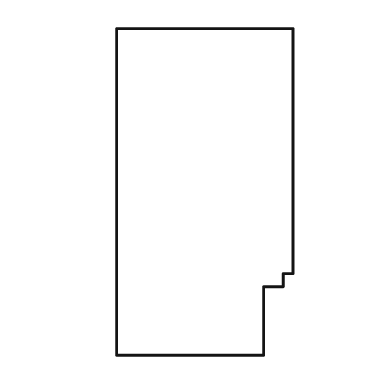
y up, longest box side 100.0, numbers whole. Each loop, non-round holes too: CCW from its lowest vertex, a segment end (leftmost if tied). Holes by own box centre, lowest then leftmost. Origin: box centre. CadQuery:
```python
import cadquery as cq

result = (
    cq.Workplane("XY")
    .moveTo(-27.0, -50.0)
    .lineTo(18.0, -50.0)
    .lineTo(18.0, -29.0)
    .lineTo(24.0, -29.0)
    .lineTo(24.0, -25.0)
    .lineTo(27.0, -25.0)
    .lineTo(27.0, 50.0)
    .lineTo(-27.0, 50.0)
    .close()
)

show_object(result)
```